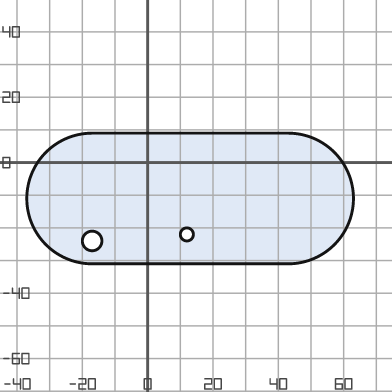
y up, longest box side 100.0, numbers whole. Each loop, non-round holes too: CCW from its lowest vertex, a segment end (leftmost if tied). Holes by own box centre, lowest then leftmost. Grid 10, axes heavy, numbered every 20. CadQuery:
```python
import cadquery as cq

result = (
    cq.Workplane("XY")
    .moveTo(-17.0, -31.0)
    .lineTo(43.0, -31.0)
    .threePointArc((63.0, -11.0), (43.0, 9.0))
    .lineTo(-17.0, 9.0)
    .threePointArc((-37.0, -11.0), (-17.0, -31.0))
    .close()
    .moveTo(-17.0, -24.0)
    .circle(3.0)
    .moveTo(12.0, -22.0)
    .circle(2.0)
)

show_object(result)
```